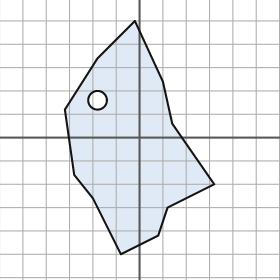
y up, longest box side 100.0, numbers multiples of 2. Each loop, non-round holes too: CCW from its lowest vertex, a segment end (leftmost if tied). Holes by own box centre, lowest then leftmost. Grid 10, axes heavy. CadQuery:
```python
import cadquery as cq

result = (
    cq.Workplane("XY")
    .moveTo(-8.0, -50.0)
    .lineTo(8.0, -42.0)
    .lineTo(12.0, -30.0)
    .lineTo(32.0, -20.0)
    .lineTo(14.0, 6.0)
    .lineTo(10.0, 24.0)
    .lineTo(-2.0, 50.0)
    .lineTo(-18.0, 34.0)
    .lineTo(-32.0, 12.0)
    .lineTo(-28.0, -16.0)
    .lineTo(-20.0, -26.0)
    .close()
    .moveTo(-18.0, 16.0)
    .circle(4.0)
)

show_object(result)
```